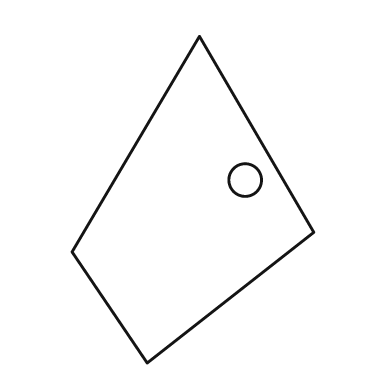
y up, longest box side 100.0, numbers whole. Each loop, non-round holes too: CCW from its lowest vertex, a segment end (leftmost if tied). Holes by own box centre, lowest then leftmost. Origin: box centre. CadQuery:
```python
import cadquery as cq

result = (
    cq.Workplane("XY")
    .moveTo(-14.0, -50.0)
    .lineTo(37.0, -10.0)
    .lineTo(2.0, 50.0)
    .lineTo(-37.0, -16.0)
    .close()
    .moveTo(16.0, 6.0)
    .circle(5.0)
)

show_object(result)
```